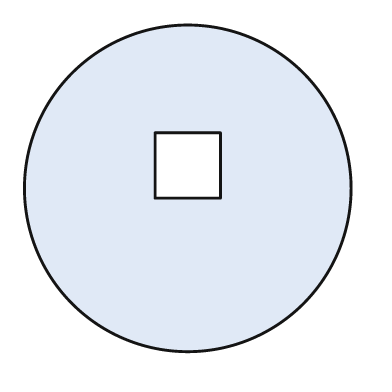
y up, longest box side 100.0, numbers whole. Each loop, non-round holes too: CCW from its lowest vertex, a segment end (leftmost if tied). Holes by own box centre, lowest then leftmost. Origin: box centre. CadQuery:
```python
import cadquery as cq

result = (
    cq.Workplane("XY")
    .moveTo(0.0, 0.0)
    .circle(50.0)
    .moveTo(-10.0, -3.0)
    .lineTo(10.0, -3.0)
    .lineTo(10.0, 17.0)
    .lineTo(-10.0, 17.0)
    .close()
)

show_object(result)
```